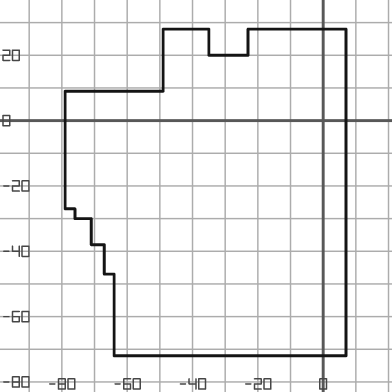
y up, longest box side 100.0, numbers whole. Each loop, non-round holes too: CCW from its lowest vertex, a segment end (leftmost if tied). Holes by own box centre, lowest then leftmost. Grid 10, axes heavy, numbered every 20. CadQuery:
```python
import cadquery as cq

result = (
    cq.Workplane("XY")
    .moveTo(-64.0, -72.0)
    .lineTo(7.0, -72.0)
    .lineTo(7.0, 28.0)
    .lineTo(-23.0, 28.0)
    .lineTo(-23.0, 20.0)
    .lineTo(-35.0, 20.0)
    .lineTo(-35.0, 28.0)
    .lineTo(-49.0, 28.0)
    .lineTo(-49.0, 9.0)
    .lineTo(-79.0, 9.0)
    .lineTo(-79.0, -27.0)
    .lineTo(-76.0, -27.0)
    .lineTo(-76.0, -30.0)
    .lineTo(-71.0, -30.0)
    .lineTo(-71.0, -38.0)
    .lineTo(-67.0, -38.0)
    .lineTo(-67.0, -47.0)
    .lineTo(-64.0, -47.0)
    .close()
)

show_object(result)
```